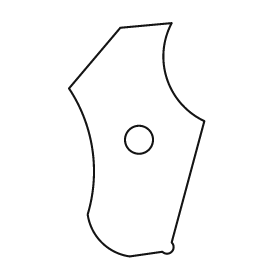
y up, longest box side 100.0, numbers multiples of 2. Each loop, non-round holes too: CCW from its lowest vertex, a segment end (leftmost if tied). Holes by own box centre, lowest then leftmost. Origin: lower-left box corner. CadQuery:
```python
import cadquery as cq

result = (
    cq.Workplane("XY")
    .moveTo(26.0, 0.0)
    .lineTo(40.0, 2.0)
    .threePointArc((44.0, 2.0), (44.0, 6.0))
    .lineTo(58.0, 58.0)
    .threePointArc((42.0, 76.0), (44.0, 100.0))
    .lineTo(22.0, 98.0)
    .lineTo(0.0, 72.0)
    .threePointArc((10.0, 46.0), (8.0, 18.0))
    .threePointArc((14.0, 6.0), (26.0, 0.0))
    .close()
    .moveTo(30.0, 50.0)
    .circle(6.0)
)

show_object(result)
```